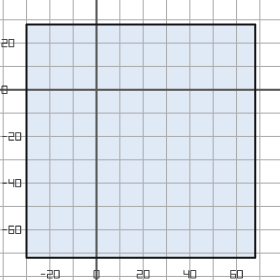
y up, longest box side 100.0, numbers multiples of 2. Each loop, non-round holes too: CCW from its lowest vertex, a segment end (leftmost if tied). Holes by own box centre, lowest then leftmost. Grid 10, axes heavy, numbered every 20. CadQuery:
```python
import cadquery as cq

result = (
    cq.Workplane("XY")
    .moveTo(-30.0, -72.0)
    .lineTo(68.0, -72.0)
    .lineTo(68.0, 28.0)
    .lineTo(-30.0, 28.0)
    .close()
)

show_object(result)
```